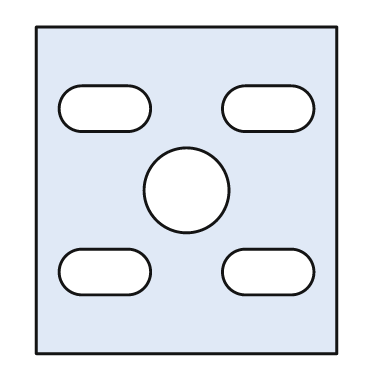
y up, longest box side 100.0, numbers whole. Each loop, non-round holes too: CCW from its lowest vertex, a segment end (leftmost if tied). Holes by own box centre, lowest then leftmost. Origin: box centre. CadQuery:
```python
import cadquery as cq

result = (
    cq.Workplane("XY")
    .moveTo(-46.0, -50.0)
    .lineTo(46.0, -50.0)
    .lineTo(46.0, 50.0)
    .lineTo(-46.0, 50.0)
    .close()
    .moveTo(-32.0, -32.0)
    .lineTo(-18.0, -32.0)
    .threePointArc((-11.0, -25.0), (-18.0, -18.0))
    .lineTo(-32.0, -18.0)
    .threePointArc((-39.0, -25.0), (-32.0, -32.0))
    .close()
    .moveTo(18.0, -32.0)
    .lineTo(32.0, -32.0)
    .threePointArc((39.0, -25.0), (32.0, -18.0))
    .lineTo(18.0, -18.0)
    .threePointArc((11.0, -25.0), (18.0, -32.0))
    .close()
    .moveTo(0.0, 0.0)
    .circle(13.0)
    .moveTo(-32.0, 18.0)
    .lineTo(-18.0, 18.0)
    .threePointArc((-11.0, 25.0), (-18.0, 32.0))
    .lineTo(-32.0, 32.0)
    .threePointArc((-39.0, 25.0), (-32.0, 18.0))
    .close()
    .moveTo(18.0, 18.0)
    .lineTo(32.0, 18.0)
    .threePointArc((39.0, 25.0), (32.0, 32.0))
    .lineTo(18.0, 32.0)
    .threePointArc((11.0, 25.0), (18.0, 18.0))
    .close()
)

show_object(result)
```